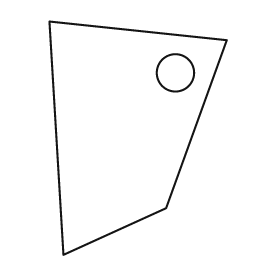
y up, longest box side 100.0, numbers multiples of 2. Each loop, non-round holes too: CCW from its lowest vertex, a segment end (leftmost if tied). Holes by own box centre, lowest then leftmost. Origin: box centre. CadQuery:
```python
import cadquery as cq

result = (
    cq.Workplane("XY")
    .moveTo(-32.0, -50.0)
    .lineTo(12.0, -30.0)
    .lineTo(38.0, 42.0)
    .lineTo(-38.0, 50.0)
    .close()
    .moveTo(16.0, 28.0)
    .circle(8.0)
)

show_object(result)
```